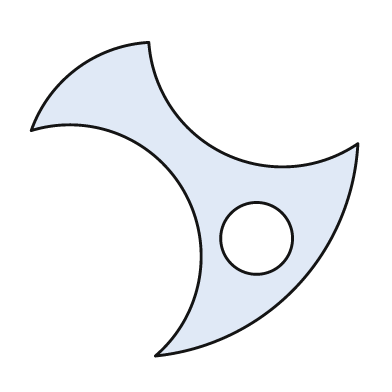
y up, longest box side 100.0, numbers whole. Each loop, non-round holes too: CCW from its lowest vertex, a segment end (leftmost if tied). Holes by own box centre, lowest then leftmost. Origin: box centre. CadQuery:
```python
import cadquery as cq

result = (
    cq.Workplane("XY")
    .moveTo(-12.0, -48.0)
    .threePointArc((31.0, -27.0), (50.0, 17.0))
    .threePointArc((9.0, 14.0), (-14.0, 48.0))
    .threePointArc((-36.0, 40.0), (-50.0, 21.0))
    .threePointArc((-3.0, 2.0), (-12.0, -48.0))
    .close()
    .moveTo(19.0, -12.0)
    .circle(11.0)
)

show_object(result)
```